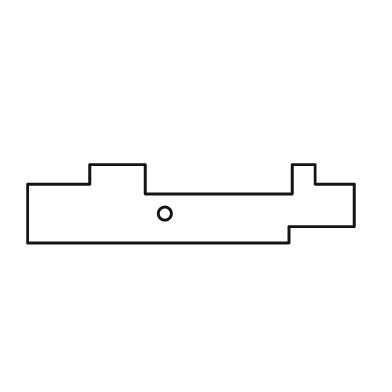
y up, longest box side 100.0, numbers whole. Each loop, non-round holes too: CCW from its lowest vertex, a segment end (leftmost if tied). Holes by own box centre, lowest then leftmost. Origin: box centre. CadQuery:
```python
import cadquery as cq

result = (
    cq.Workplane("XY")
    .moveTo(-50.0, -12.0)
    .lineTo(30.0, -12.0)
    .lineTo(30.0, -7.0)
    .lineTo(50.0, -7.0)
    .lineTo(50.0, 6.0)
    .lineTo(38.0, 6.0)
    .lineTo(38.0, 12.0)
    .lineTo(31.0, 12.0)
    .lineTo(31.0, 3.0)
    .lineTo(-14.0, 3.0)
    .lineTo(-14.0, 12.0)
    .lineTo(-31.0, 12.0)
    .lineTo(-31.0, 6.0)
    .lineTo(-50.0, 6.0)
    .close()
    .moveTo(-8.0, -3.0)
    .circle(2.0)
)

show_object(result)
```